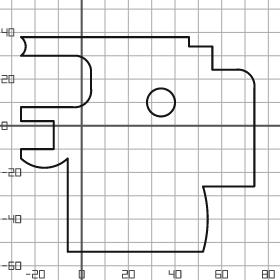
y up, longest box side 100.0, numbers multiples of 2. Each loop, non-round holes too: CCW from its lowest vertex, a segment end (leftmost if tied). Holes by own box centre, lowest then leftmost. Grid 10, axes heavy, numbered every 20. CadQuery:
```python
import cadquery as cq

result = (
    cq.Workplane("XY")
    .moveTo(-6.0, -54.0)
    .lineTo(52.0, -54.0)
    .threePointArc((54.0, -40.0), (52.0, -26.0))
    .lineTo(74.0, -26.0)
    .lineTo(74.0, 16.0)
    .threePointArc((72.0, 22.0), (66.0, 24.0))
    .lineTo(56.0, 24.0)
    .lineTo(56.0, 34.0)
    .lineTo(46.0, 34.0)
    .lineTo(46.0, 38.0)
    .lineTo(-26.0, 38.0)
    .threePointArc((-24.0, 34.0), (-26.0, 30.0))
    .lineTo(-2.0, 30.0)
    .threePointArc((2.0, 28.0), (4.0, 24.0))
    .lineTo(4.0, 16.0)
    .threePointArc((2.0, 10.0), (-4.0, 8.0))
    .lineTo(-26.0, 8.0)
    .lineTo(-26.0, 2.0)
    .lineTo(-12.0, 2.0)
    .lineTo(-12.0, -10.0)
    .lineTo(-26.0, -10.0)
    .lineTo(-26.0, -14.0)
    .threePointArc((-16.0, -18.0), (-6.0, -14.0))
    .close()
    .moveTo(34.0, 10.0)
    .circle(6.0)
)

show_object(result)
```